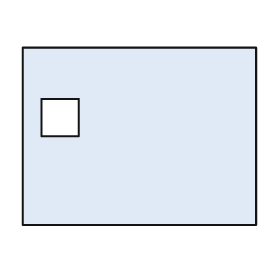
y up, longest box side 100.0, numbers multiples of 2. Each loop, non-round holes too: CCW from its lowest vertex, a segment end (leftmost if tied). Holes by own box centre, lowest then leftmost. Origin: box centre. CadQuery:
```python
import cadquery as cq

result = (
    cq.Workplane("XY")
    .moveTo(-50.0, -38.0)
    .lineTo(50.0, -38.0)
    .lineTo(50.0, 38.0)
    .lineTo(-50.0, 38.0)
    .close()
    .moveTo(-42.0, 0.0)
    .lineTo(-26.0, 0.0)
    .lineTo(-26.0, 16.0)
    .lineTo(-42.0, 16.0)
    .close()
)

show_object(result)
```